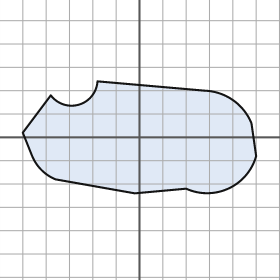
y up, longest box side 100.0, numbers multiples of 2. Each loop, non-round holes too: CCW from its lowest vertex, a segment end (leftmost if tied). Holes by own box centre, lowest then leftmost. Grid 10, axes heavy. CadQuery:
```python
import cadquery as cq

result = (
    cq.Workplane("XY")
    .moveTo(-2.0, -24.0)
    .lineTo(20.0, -22.0)
    .threePointArc((38.0, -22.0), (50.0, -8.0))
    .lineTo(48.0, 6.0)
    .threePointArc((40.0, 16.0), (28.0, 20.0))
    .lineTo(-18.0, 24.0)
    .threePointArc((-26.0, 14.0), (-38.0, 18.0))
    .lineTo(-50.0, 2.0)
    .lineTo(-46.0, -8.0)
    .threePointArc((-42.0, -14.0), (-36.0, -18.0))
    .close()
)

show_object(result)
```